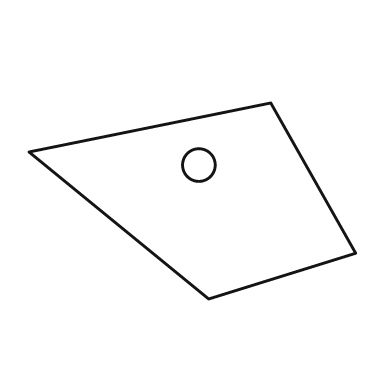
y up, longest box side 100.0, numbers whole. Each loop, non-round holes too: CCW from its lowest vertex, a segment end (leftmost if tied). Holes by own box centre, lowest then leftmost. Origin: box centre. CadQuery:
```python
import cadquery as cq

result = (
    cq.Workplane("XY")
    .moveTo(5.0, -30.0)
    .lineTo(50.0, -16.0)
    .lineTo(24.0, 30.0)
    .lineTo(-50.0, 15.0)
    .close()
    .moveTo(2.0, 11.0)
    .circle(5.0)
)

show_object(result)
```